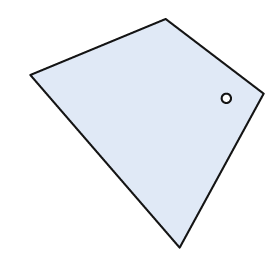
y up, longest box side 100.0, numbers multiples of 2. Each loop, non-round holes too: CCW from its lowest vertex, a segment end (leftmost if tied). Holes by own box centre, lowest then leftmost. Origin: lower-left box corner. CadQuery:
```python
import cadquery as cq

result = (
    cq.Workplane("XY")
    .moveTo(64.0, 0.0)
    .lineTo(100.0, 66.0)
    .lineTo(58.0, 98.0)
    .lineTo(0.0, 74.0)
    .close()
    .moveTo(84.0, 64.0)
    .circle(2.0)
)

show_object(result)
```